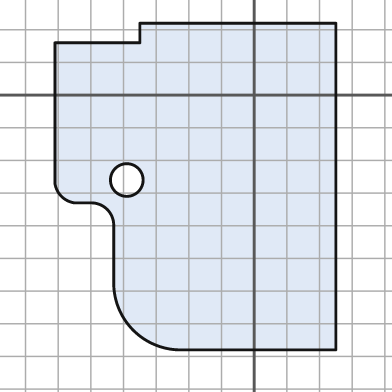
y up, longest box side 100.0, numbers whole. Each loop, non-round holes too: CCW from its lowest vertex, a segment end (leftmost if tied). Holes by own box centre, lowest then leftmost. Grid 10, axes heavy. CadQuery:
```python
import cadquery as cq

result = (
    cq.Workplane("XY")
    .moveTo(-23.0, -78.0)
    .lineTo(25.0, -78.0)
    .lineTo(25.0, 22.0)
    .lineTo(-35.0, 22.0)
    .lineTo(-35.0, 16.0)
    .lineTo(-61.0, 16.0)
    .lineTo(-61.0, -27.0)
    .threePointArc((-59.0, -31.0), (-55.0, -33.0))
    .lineTo(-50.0, -33.0)
    .threePointArc((-45.0, -35.0), (-43.0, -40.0))
    .lineTo(-43.0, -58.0)
    .threePointArc((-37.0, -72.0), (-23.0, -78.0))
    .close()
    .moveTo(-39.0, -26.0)
    .circle(5.0)
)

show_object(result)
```